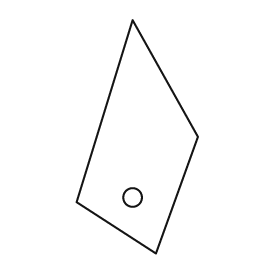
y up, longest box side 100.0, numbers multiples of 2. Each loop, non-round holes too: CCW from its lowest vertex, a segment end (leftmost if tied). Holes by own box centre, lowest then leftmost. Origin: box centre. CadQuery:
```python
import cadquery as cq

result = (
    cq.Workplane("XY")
    .moveTo(8.0, -50.0)
    .lineTo(26.0, 0.0)
    .lineTo(-2.0, 50.0)
    .lineTo(-26.0, -28.0)
    .close()
    .moveTo(-2.0, -26.0)
    .circle(4.0)
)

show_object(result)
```